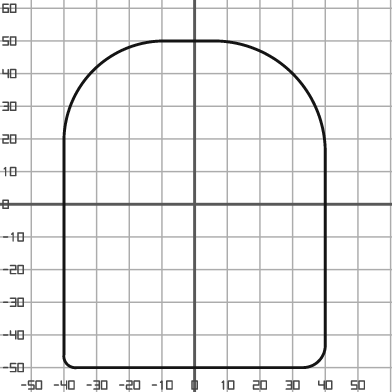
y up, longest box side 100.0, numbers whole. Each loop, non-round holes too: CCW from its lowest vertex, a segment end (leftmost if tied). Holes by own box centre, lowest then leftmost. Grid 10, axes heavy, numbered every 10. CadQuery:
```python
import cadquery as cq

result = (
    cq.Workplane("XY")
    .moveTo(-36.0, -50.0)
    .lineTo(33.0, -50.0)
    .threePointArc((38.0, -48.0), (40.0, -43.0))
    .lineTo(40.0, 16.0)
    .threePointArc((30.0, 40.0), (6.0, 50.0))
    .lineTo(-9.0, 50.0)
    .threePointArc((-31.0, 41.0), (-40.0, 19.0))
    .lineTo(-40.0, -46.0)
    .threePointArc((-39.0, -49.0), (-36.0, -50.0))
    .close()
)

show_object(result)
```